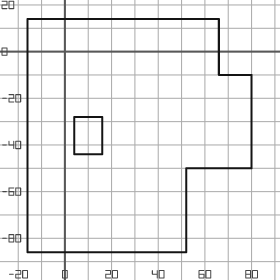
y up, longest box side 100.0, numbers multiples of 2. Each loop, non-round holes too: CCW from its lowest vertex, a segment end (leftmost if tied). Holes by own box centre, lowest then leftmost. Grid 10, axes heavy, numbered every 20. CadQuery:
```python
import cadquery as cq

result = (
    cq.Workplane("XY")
    .moveTo(-16.0, -86.0)
    .lineTo(52.0, -86.0)
    .lineTo(52.0, -50.0)
    .lineTo(80.0, -50.0)
    .lineTo(80.0, -10.0)
    .lineTo(66.0, -10.0)
    .lineTo(66.0, 14.0)
    .lineTo(-16.0, 14.0)
    .close()
    .moveTo(4.0, -44.0)
    .lineTo(16.0, -44.0)
    .lineTo(16.0, -28.0)
    .lineTo(4.0, -28.0)
    .close()
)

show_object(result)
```